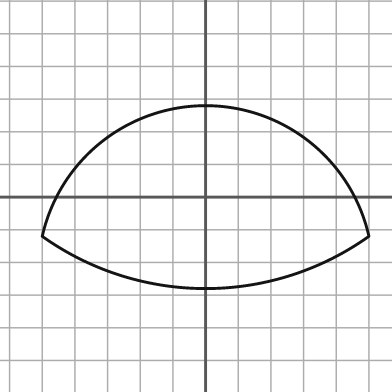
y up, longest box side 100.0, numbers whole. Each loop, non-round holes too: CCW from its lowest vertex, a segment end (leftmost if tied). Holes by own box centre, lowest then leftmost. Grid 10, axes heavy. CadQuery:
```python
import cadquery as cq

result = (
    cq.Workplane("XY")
    .moveTo(-50.0, -12.0)
    .threePointArc((0.0, -28.0), (50.0, -12.0))
    .threePointArc((0.0, 28.0), (-50.0, -12.0))
    .close()
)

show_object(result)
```